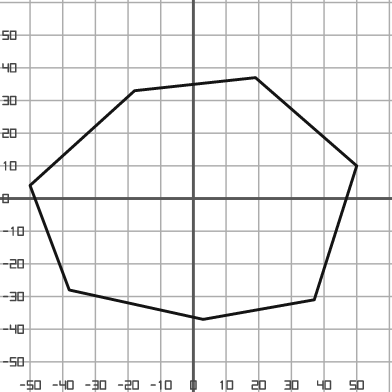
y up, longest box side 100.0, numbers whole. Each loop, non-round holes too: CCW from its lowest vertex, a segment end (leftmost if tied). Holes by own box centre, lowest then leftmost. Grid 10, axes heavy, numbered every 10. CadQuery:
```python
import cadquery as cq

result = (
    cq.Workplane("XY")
    .moveTo(3.0, -37.0)
    .lineTo(37.0, -31.0)
    .lineTo(50.0, 10.0)
    .lineTo(19.0, 37.0)
    .lineTo(-18.0, 33.0)
    .lineTo(-50.0, 4.0)
    .lineTo(-38.0, -28.0)
    .close()
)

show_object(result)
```